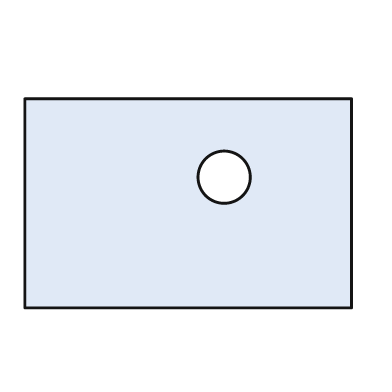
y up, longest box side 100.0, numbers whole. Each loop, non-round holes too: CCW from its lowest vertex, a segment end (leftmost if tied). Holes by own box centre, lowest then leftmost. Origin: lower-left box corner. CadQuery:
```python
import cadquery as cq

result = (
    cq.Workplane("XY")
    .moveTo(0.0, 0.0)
    .lineTo(100.0, 0.0)
    .lineTo(100.0, 64.0)
    .lineTo(0.0, 64.0)
    .close()
    .moveTo(61.0, 40.0)
    .circle(8.0)
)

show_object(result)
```